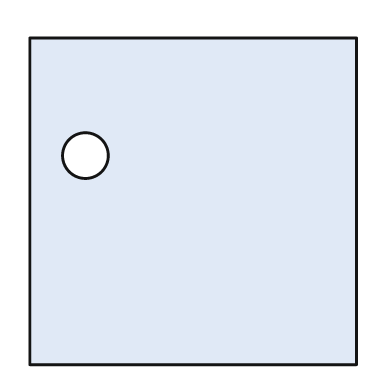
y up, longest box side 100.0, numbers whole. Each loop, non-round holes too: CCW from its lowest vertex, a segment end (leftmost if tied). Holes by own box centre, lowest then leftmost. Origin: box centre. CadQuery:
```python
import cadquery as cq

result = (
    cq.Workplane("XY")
    .moveTo(-50.0, -50.0)
    .lineTo(50.0, -50.0)
    .lineTo(50.0, 50.0)
    .lineTo(-50.0, 50.0)
    .close()
    .moveTo(-33.0, 14.0)
    .circle(7.0)
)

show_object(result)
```